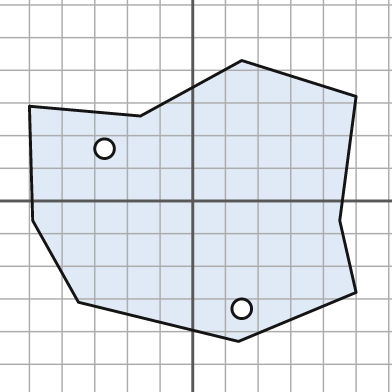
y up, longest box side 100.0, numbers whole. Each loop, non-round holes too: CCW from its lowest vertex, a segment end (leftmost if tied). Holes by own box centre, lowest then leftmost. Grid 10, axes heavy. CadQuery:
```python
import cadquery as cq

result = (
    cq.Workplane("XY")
    .moveTo(14.0, -43.0)
    .lineTo(50.0, -28.0)
    .lineTo(45.0, -6.0)
    .lineTo(50.0, 32.0)
    .lineTo(15.0, 43.0)
    .lineTo(-16.0, 26.0)
    .lineTo(-50.0, 29.0)
    .lineTo(-49.0, -6.0)
    .lineTo(-35.0, -31.0)
    .close()
    .moveTo(15.0, -33.0)
    .circle(3.0)
    .moveTo(-27.0, 16.0)
    .circle(3.0)
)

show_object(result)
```